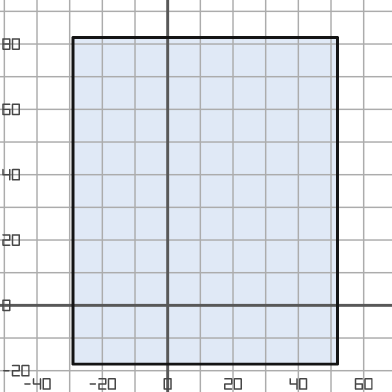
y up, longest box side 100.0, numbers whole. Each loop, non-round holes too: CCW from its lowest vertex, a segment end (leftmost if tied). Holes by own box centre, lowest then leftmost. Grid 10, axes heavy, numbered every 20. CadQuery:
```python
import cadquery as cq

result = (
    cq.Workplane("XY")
    .moveTo(-29.0, -18.0)
    .lineTo(52.0, -18.0)
    .lineTo(52.0, 82.0)
    .lineTo(-29.0, 82.0)
    .close()
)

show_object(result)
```